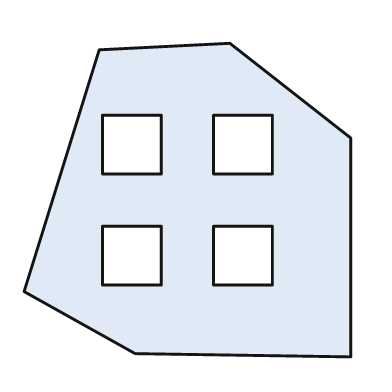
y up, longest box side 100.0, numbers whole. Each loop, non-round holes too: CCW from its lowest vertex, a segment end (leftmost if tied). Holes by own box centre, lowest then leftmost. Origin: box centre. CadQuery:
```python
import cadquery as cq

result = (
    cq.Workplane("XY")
    .moveTo(50.0, -48.0)
    .lineTo(50.0, 19.0)
    .lineTo(13.0, 48.0)
    .lineTo(-27.0, 46.0)
    .lineTo(-50.0, -28.0)
    .lineTo(-16.0, -47.0)
    .close()
    .moveTo(-26.0, -26.0)
    .lineTo(-8.0, -26.0)
    .lineTo(-8.0, -8.0)
    .lineTo(-26.0, -8.0)
    .close()
    .moveTo(8.0, -26.0)
    .lineTo(26.0, -26.0)
    .lineTo(26.0, -8.0)
    .lineTo(8.0, -8.0)
    .close()
    .moveTo(-26.0, 8.0)
    .lineTo(-8.0, 8.0)
    .lineTo(-8.0, 26.0)
    .lineTo(-26.0, 26.0)
    .close()
    .moveTo(8.0, 8.0)
    .lineTo(26.0, 8.0)
    .lineTo(26.0, 26.0)
    .lineTo(8.0, 26.0)
    .close()
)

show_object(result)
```